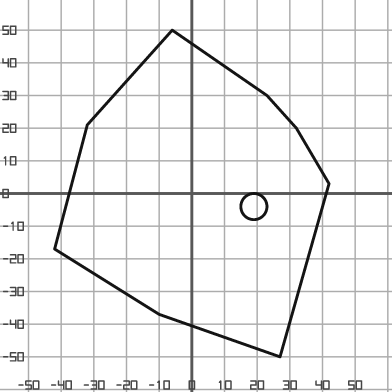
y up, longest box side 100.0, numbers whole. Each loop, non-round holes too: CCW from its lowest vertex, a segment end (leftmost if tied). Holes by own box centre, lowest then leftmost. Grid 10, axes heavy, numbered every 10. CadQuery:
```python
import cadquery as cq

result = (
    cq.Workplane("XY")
    .moveTo(27.0, -50.0)
    .lineTo(42.0, 3.0)
    .lineTo(32.0, 20.0)
    .lineTo(23.0, 30.0)
    .lineTo(-6.0, 50.0)
    .lineTo(-32.0, 21.0)
    .lineTo(-42.0, -17.0)
    .lineTo(-10.0, -37.0)
    .close()
    .moveTo(19.0, -4.0)
    .circle(4.0)
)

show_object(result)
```